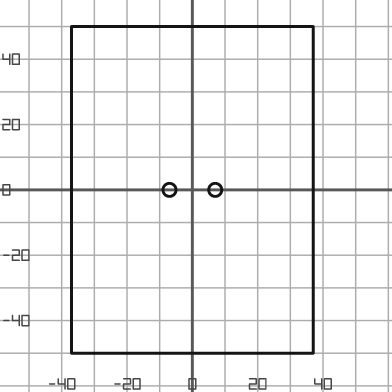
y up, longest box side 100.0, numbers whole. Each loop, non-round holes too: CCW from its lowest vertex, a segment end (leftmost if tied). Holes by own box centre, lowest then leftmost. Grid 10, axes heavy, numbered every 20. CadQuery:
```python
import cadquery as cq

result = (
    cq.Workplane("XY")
    .moveTo(-37.0, -50.0)
    .lineTo(37.0, -50.0)
    .lineTo(37.0, 50.0)
    .lineTo(-37.0, 50.0)
    .close()
    .moveTo(-7.0, 0.0)
    .circle(2.0)
    .moveTo(7.0, 0.0)
    .circle(2.0)
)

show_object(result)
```